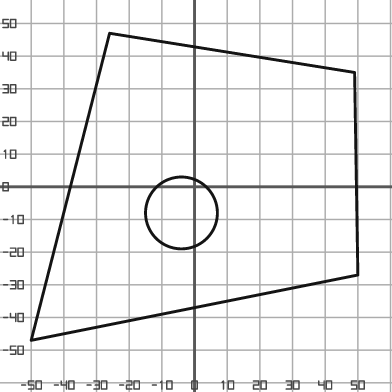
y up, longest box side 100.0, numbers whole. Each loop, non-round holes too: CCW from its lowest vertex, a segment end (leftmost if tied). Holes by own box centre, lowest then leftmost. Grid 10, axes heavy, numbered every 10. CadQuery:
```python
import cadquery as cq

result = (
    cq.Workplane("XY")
    .moveTo(-50.0, -47.0)
    .lineTo(50.0, -27.0)
    .lineTo(49.0, 35.0)
    .lineTo(-26.0, 47.0)
    .close()
    .moveTo(-4.0, -8.0)
    .circle(11.0)
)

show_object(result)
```